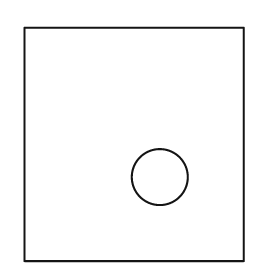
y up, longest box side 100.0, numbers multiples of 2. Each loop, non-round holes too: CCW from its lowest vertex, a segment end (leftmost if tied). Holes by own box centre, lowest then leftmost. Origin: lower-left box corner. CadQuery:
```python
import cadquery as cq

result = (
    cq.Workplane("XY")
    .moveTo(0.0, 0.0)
    .lineTo(94.0, 0.0)
    .lineTo(94.0, 100.0)
    .lineTo(0.0, 100.0)
    .close()
    .moveTo(58.0, 36.0)
    .circle(12.0)
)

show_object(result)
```